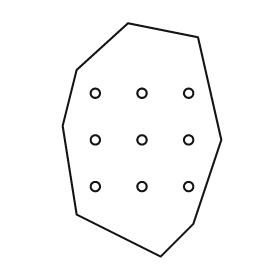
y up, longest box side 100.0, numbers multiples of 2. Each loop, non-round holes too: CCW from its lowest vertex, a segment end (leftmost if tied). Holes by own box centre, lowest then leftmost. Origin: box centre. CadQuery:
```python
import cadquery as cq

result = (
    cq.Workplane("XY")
    .moveTo(8.0, -50.0)
    .lineTo(22.0, -36.0)
    .lineTo(34.0, 0.0)
    .lineTo(24.0, 44.0)
    .lineTo(-6.0, 50.0)
    .lineTo(-28.0, 30.0)
    .lineTo(-34.0, 6.0)
    .lineTo(-28.0, -32.0)
    .close()
    .moveTo(-20.0, -20.0)
    .circle(2.0)
    .moveTo(0.0, -20.0)
    .circle(2.0)
    .moveTo(20.0, -20.0)
    .circle(2.0)
    .moveTo(-20.0, 0.0)
    .circle(2.0)
    .moveTo(0.0, 0.0)
    .circle(2.0)
    .moveTo(20.0, 0.0)
    .circle(2.0)
    .moveTo(-20.0, 20.0)
    .circle(2.0)
    .moveTo(0.0, 20.0)
    .circle(2.0)
    .moveTo(20.0, 20.0)
    .circle(2.0)
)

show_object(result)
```